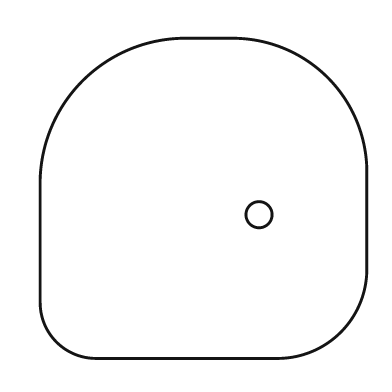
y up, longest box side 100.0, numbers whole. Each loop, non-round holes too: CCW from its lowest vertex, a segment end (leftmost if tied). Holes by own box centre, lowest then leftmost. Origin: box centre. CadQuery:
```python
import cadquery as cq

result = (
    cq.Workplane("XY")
    .moveTo(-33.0, -49.0)
    .lineTo(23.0, -49.0)
    .threePointArc((42.0, -41.0), (50.0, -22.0))
    .lineTo(50.0, 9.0)
    .threePointArc((38.0, 37.0), (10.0, 49.0))
    .lineTo(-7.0, 49.0)
    .threePointArc((-37.0, 36.0), (-50.0, 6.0))
    .lineTo(-50.0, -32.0)
    .threePointArc((-45.0, -44.0), (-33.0, -49.0))
    .close()
    .moveTo(17.0, -5.0)
    .circle(4.0)
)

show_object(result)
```